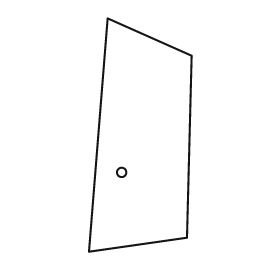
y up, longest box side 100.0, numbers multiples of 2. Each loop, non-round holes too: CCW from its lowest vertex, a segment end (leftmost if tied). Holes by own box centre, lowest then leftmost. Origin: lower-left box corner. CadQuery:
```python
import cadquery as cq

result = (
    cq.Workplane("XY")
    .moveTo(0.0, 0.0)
    .lineTo(42.0, 6.0)
    .lineTo(44.0, 84.0)
    .lineTo(8.0, 100.0)
    .close()
    .moveTo(14.0, 34.0)
    .circle(2.0)
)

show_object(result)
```